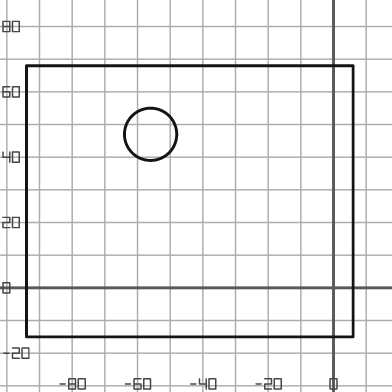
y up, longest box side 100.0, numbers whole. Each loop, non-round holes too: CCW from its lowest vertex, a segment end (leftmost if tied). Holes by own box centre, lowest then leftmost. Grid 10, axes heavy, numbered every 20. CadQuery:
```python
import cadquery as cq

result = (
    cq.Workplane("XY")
    .moveTo(-94.0, -15.0)
    .lineTo(6.0, -15.0)
    .lineTo(6.0, 68.0)
    .lineTo(-94.0, 68.0)
    .close()
    .moveTo(-56.0, 47.0)
    .circle(8.0)
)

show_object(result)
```